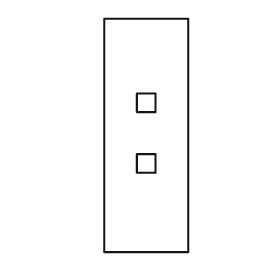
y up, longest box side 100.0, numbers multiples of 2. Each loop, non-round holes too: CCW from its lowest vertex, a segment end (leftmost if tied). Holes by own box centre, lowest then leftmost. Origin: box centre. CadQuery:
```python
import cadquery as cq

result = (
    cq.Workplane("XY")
    .moveTo(-18.0, -50.0)
    .lineTo(18.0, -50.0)
    .lineTo(18.0, 50.0)
    .lineTo(-18.0, 50.0)
    .close()
    .moveTo(-4.0, -16.0)
    .lineTo(4.0, -16.0)
    .lineTo(4.0, -8.0)
    .lineTo(-4.0, -8.0)
    .close()
    .moveTo(-4.0, 10.0)
    .lineTo(4.0, 10.0)
    .lineTo(4.0, 18.0)
    .lineTo(-4.0, 18.0)
    .close()
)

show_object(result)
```